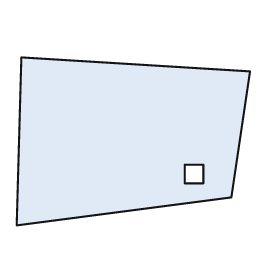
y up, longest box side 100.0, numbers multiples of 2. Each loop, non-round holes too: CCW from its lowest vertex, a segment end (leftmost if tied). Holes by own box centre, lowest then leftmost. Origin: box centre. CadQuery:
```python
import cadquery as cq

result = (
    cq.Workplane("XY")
    .moveTo(-50.0, -36.0)
    .lineTo(42.0, -24.0)
    .lineTo(50.0, 30.0)
    .lineTo(-48.0, 36.0)
    .close()
    .moveTo(22.0, -18.0)
    .lineTo(30.0, -18.0)
    .lineTo(30.0, -10.0)
    .lineTo(22.0, -10.0)
    .close()
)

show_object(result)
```